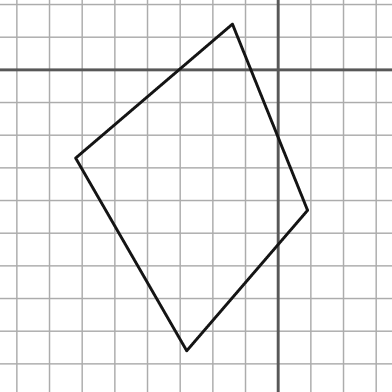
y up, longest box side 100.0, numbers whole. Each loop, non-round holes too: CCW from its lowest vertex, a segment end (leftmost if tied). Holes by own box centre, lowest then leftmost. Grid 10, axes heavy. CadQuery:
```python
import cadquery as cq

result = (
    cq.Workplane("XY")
    .moveTo(-28.0, -86.0)
    .lineTo(9.0, -43.0)
    .lineTo(-14.0, 14.0)
    .lineTo(-62.0, -27.0)
    .close()
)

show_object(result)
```